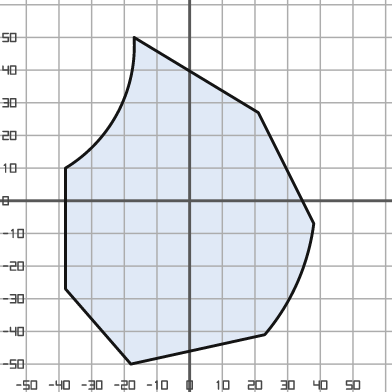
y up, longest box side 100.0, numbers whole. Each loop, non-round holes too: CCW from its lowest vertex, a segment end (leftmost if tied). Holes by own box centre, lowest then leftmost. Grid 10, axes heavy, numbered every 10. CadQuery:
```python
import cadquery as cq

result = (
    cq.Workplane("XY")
    .moveTo(-18.0, -50.0)
    .lineTo(23.0, -41.0)
    .threePointArc((33.0, -25.0), (38.0, -7.0))
    .lineTo(21.0, 27.0)
    .lineTo(-17.0, 50.0)
    .threePointArc((-22.0, 27.0), (-38.0, 10.0))
    .lineTo(-38.0, -27.0)
    .close()
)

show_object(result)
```